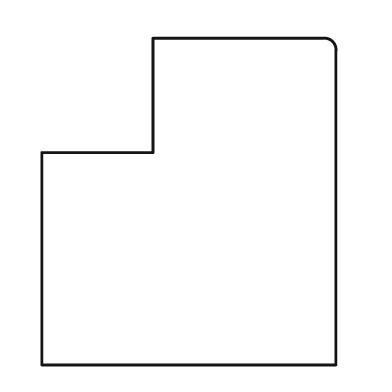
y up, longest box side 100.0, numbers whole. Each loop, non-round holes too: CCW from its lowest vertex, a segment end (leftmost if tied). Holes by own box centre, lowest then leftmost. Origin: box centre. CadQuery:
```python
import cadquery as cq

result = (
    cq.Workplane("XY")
    .moveTo(-45.0, -50.0)
    .lineTo(45.0, -50.0)
    .lineTo(45.0, 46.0)
    .threePointArc((44.0, 49.0), (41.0, 50.0))
    .lineTo(-11.0, 50.0)
    .lineTo(-11.0, 15.0)
    .lineTo(-45.0, 15.0)
    .close()
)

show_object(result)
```